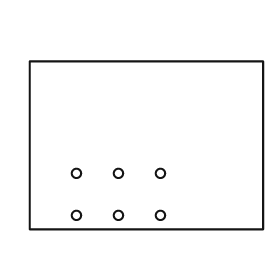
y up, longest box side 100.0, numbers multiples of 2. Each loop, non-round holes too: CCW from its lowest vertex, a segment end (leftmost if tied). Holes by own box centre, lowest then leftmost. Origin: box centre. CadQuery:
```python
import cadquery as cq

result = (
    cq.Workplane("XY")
    .moveTo(-50.0, -36.0)
    .lineTo(50.0, -36.0)
    .lineTo(50.0, 36.0)
    .lineTo(-50.0, 36.0)
    .close()
    .moveTo(-30.0, -30.0)
    .circle(2.0)
    .moveTo(-12.0, -30.0)
    .circle(2.0)
    .moveTo(6.0, -30.0)
    .circle(2.0)
    .moveTo(-30.0, -12.0)
    .circle(2.0)
    .moveTo(-12.0, -12.0)
    .circle(2.0)
    .moveTo(6.0, -12.0)
    .circle(2.0)
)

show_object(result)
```